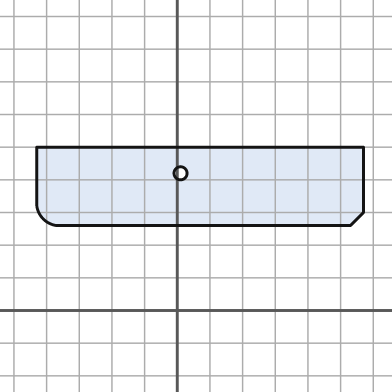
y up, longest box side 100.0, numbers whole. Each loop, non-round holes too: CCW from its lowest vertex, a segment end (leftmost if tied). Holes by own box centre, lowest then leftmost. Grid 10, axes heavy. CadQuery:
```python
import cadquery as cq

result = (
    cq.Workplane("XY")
    .moveTo(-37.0, 26.0)
    .lineTo(53.0, 26.0)
    .lineTo(57.0, 30.0)
    .lineTo(57.0, 50.0)
    .lineTo(-43.0, 50.0)
    .lineTo(-43.0, 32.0)
    .threePointArc((-41.0, 28.0), (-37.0, 26.0))
    .close()
    .moveTo(1.0, 42.0)
    .circle(2.0)
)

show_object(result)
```